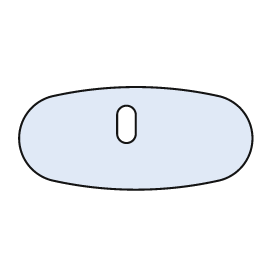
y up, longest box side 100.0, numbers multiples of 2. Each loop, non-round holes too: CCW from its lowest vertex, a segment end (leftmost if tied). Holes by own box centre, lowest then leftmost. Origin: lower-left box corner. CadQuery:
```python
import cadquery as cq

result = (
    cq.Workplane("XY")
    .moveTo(14.0, 4.0)
    .threePointArc((50.0, 0.0), (86.0, 4.0))
    .threePointArc((100.0, 22.0), (86.0, 40.0))
    .threePointArc((50.0, 44.0), (14.0, 40.0))
    .threePointArc((0.0, 22.0), (14.0, 4.0))
    .close()
    .moveTo(42.0, 24.0)
    .threePointArc((46.0, 20.0), (50.0, 24.0))
    .lineTo(50.0, 32.0)
    .threePointArc((46.0, 36.0), (42.0, 32.0))
    .close()
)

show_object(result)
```